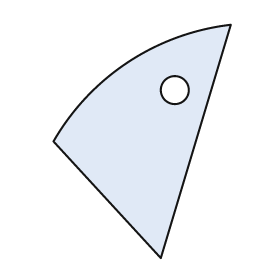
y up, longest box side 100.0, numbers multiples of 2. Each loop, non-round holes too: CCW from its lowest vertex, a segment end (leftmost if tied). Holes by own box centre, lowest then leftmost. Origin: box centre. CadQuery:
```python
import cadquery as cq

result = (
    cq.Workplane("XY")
    .moveTo(8.0, -50.0)
    .lineTo(38.0, 50.0)
    .threePointArc((-6.0, 34.0), (-38.0, 0.0))
    .close()
    .moveTo(14.0, 22.0)
    .circle(6.0)
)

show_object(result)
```